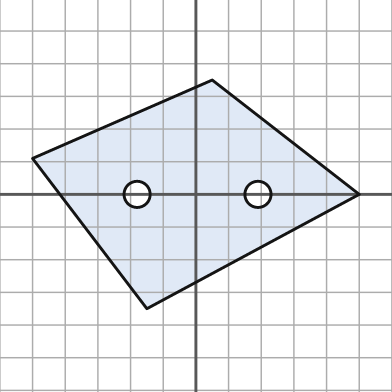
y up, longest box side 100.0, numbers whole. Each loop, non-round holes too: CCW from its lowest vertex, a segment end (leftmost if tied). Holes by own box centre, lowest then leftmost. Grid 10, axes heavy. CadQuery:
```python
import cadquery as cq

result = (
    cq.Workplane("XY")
    .moveTo(-15.0, -35.0)
    .lineTo(50.0, 0.0)
    .lineTo(5.0, 35.0)
    .lineTo(-50.0, 11.0)
    .close()
    .moveTo(-18.0, 0.0)
    .circle(4.0)
    .moveTo(19.0, 0.0)
    .circle(4.0)
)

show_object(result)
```